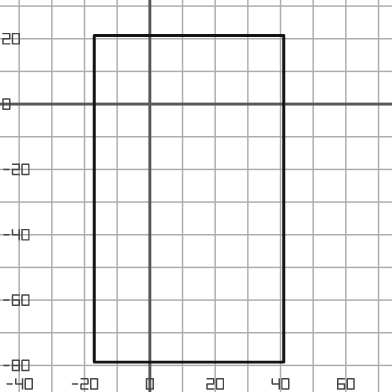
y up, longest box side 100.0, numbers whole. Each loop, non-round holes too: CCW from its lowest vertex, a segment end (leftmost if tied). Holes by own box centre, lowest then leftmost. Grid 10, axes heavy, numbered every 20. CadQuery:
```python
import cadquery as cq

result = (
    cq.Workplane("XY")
    .moveTo(-17.0, -79.0)
    .lineTo(41.0, -79.0)
    .lineTo(41.0, 21.0)
    .lineTo(-17.0, 21.0)
    .close()
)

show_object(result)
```